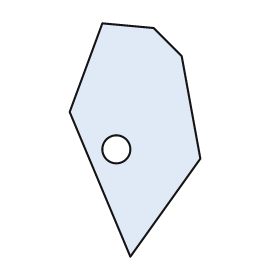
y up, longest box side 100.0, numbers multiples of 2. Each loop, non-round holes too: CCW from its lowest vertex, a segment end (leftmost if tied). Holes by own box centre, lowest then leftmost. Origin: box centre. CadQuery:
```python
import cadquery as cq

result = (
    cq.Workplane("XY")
    .moveTo(-2.0, -50.0)
    .lineTo(28.0, -8.0)
    .lineTo(20.0, 36.0)
    .lineTo(8.0, 48.0)
    .lineTo(-14.0, 50.0)
    .lineTo(-28.0, 12.0)
    .close()
    .moveTo(-8.0, -4.0)
    .circle(6.0)
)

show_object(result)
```